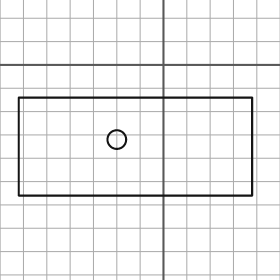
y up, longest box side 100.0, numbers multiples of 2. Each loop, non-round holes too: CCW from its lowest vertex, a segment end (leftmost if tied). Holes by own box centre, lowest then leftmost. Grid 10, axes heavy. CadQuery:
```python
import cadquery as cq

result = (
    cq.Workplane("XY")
    .moveTo(-62.0, -56.0)
    .lineTo(38.0, -56.0)
    .lineTo(38.0, -14.0)
    .lineTo(-62.0, -14.0)
    .close()
    .moveTo(-20.0, -32.0)
    .circle(4.0)
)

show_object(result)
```